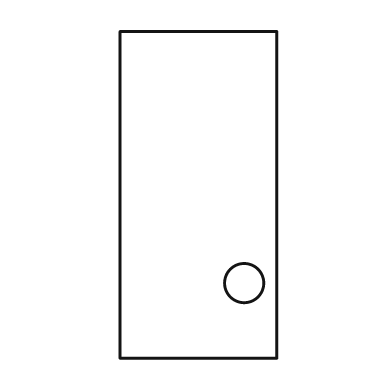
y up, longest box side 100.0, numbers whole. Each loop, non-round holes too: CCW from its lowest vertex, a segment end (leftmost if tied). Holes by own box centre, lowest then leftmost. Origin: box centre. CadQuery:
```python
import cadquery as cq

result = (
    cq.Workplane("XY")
    .moveTo(-24.0, -50.0)
    .lineTo(24.0, -50.0)
    .lineTo(24.0, 50.0)
    .lineTo(-24.0, 50.0)
    .close()
    .moveTo(14.0, -27.0)
    .circle(6.0)
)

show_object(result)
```